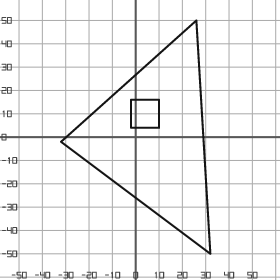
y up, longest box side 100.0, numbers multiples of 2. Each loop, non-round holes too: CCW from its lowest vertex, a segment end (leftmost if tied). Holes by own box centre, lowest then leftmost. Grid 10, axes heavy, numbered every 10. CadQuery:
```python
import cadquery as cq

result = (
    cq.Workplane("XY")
    .moveTo(32.0, -50.0)
    .lineTo(26.0, 50.0)
    .lineTo(-32.0, -2.0)
    .close()
    .moveTo(-2.0, 4.0)
    .lineTo(10.0, 4.0)
    .lineTo(10.0, 16.0)
    .lineTo(-2.0, 16.0)
    .close()
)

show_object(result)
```